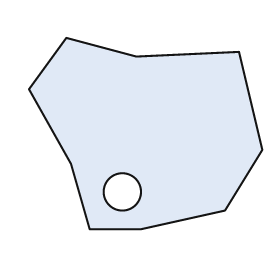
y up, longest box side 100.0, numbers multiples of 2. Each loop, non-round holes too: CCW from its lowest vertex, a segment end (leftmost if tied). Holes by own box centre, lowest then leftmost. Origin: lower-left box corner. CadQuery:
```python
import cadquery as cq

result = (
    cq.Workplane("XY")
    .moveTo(26.0, 0.0)
    .lineTo(48.0, 0.0)
    .lineTo(84.0, 8.0)
    .lineTo(100.0, 34.0)
    .lineTo(90.0, 76.0)
    .lineTo(46.0, 74.0)
    .lineTo(16.0, 82.0)
    .lineTo(0.0, 60.0)
    .lineTo(18.0, 28.0)
    .close()
    .moveTo(40.0, 16.0)
    .circle(8.0)
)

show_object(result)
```